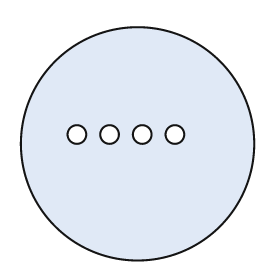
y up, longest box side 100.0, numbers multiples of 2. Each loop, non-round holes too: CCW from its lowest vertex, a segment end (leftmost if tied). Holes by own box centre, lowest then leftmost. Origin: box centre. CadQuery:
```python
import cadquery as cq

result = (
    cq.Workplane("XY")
    .moveTo(0.0, 0.0)
    .circle(50.0)
    .moveTo(-26.0, 4.0)
    .circle(4.0)
    .moveTo(-12.0, 4.0)
    .circle(4.0)
    .moveTo(2.0, 4.0)
    .circle(4.0)
    .moveTo(16.0, 4.0)
    .circle(4.0)
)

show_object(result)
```